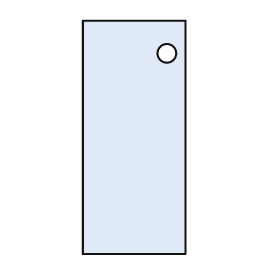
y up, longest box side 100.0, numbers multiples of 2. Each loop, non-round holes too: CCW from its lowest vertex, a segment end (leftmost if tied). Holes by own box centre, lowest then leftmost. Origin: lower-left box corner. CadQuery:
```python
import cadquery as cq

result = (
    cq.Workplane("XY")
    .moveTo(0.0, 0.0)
    .lineTo(44.0, 0.0)
    .lineTo(44.0, 100.0)
    .lineTo(0.0, 100.0)
    .close()
    .moveTo(36.0, 86.0)
    .circle(4.0)
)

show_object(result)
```